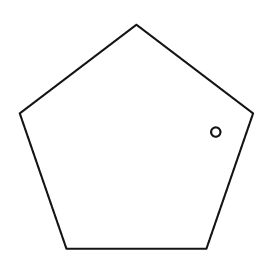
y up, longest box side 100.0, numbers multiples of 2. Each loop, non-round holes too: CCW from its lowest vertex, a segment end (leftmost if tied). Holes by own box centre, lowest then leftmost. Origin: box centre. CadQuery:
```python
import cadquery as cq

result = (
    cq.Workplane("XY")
    .moveTo(-30.0, -48.0)
    .lineTo(30.0, -48.0)
    .lineTo(50.0, 10.0)
    .lineTo(0.0, 48.0)
    .lineTo(-50.0, 10.0)
    .close()
    .moveTo(34.0, 2.0)
    .circle(2.0)
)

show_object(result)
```